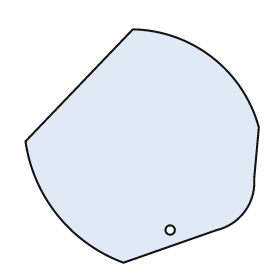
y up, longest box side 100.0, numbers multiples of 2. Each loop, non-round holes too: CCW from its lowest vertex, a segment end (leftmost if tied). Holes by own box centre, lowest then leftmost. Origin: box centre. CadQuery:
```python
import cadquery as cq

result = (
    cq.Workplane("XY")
    .moveTo(-8.0, -50.0)
    .lineTo(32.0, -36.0)
    .threePointArc((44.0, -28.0), (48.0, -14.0))
    .lineTo(50.0, 8.0)
    .threePointArc((30.0, 38.0), (-4.0, 50.0))
    .lineTo(-50.0, 2.0)
    .threePointArc((-36.0, -30.0), (-8.0, -50.0))
    .close()
    .moveTo(12.0, -36.0)
    .circle(2.0)
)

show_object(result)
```